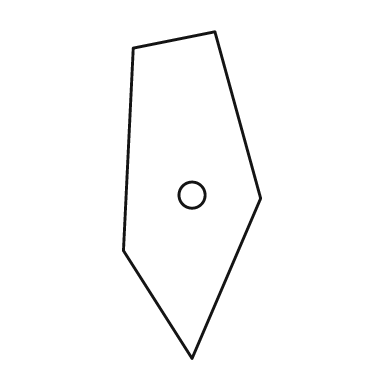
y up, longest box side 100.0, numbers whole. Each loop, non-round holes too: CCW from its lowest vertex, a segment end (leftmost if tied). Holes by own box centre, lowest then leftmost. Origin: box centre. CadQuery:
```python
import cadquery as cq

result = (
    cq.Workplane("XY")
    .moveTo(0.0, -50.0)
    .lineTo(21.0, -1.0)
    .lineTo(7.0, 50.0)
    .lineTo(-18.0, 45.0)
    .lineTo(-21.0, -17.0)
    .close()
    .moveTo(0.0, 0.0)
    .circle(4.0)
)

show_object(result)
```